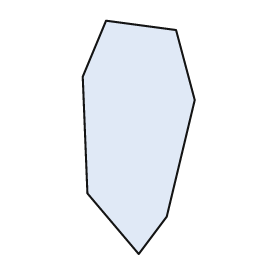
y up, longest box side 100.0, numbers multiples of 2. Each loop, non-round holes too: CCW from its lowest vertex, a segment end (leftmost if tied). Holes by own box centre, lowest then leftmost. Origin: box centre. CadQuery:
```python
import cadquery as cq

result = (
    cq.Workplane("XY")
    .moveTo(0.0, -50.0)
    .lineTo(12.0, -34.0)
    .lineTo(24.0, 16.0)
    .lineTo(16.0, 46.0)
    .lineTo(-14.0, 50.0)
    .lineTo(-24.0, 26.0)
    .lineTo(-22.0, -24.0)
    .close()
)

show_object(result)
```